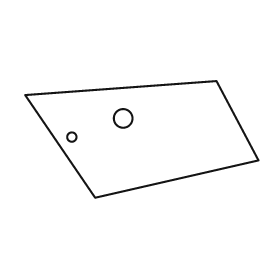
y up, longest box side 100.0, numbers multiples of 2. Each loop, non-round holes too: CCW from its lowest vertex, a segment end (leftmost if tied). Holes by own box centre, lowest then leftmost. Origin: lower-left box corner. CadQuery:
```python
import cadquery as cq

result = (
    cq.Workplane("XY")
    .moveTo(30.0, 0.0)
    .lineTo(100.0, 16.0)
    .lineTo(82.0, 50.0)
    .lineTo(0.0, 44.0)
    .close()
    .moveTo(20.0, 26.0)
    .circle(2.0)
    .moveTo(42.0, 34.0)
    .circle(4.0)
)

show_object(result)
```